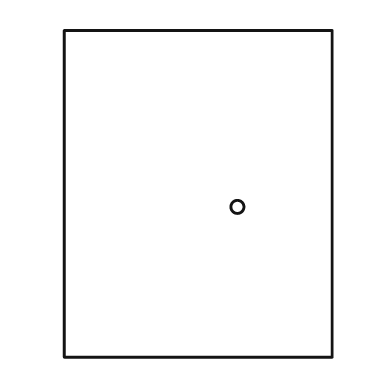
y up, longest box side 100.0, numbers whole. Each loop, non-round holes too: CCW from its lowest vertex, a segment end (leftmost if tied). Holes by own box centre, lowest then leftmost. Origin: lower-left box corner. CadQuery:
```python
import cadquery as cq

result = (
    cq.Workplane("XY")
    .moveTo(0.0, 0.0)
    .lineTo(82.0, 0.0)
    .lineTo(82.0, 100.0)
    .lineTo(0.0, 100.0)
    .close()
    .moveTo(53.0, 46.0)
    .circle(2.0)
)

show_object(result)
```